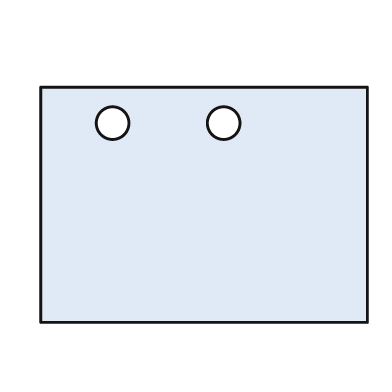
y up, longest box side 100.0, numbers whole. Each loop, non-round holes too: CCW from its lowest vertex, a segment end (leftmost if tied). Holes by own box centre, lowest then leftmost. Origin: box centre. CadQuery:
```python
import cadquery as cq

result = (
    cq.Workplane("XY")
    .moveTo(-50.0, -36.0)
    .lineTo(50.0, -36.0)
    .lineTo(50.0, 36.0)
    .lineTo(-50.0, 36.0)
    .close()
    .moveTo(-28.0, 25.0)
    .circle(5.0)
    .moveTo(6.0, 25.0)
    .circle(5.0)
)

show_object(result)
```